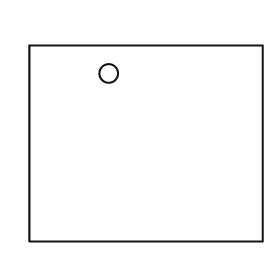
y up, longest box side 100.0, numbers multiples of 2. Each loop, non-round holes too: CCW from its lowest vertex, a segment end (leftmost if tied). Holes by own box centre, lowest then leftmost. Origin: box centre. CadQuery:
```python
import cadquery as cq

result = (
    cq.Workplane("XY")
    .moveTo(-50.0, -42.0)
    .lineTo(50.0, -42.0)
    .lineTo(50.0, 42.0)
    .lineTo(-50.0, 42.0)
    .close()
    .moveTo(-16.0, 30.0)
    .circle(4.0)
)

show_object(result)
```